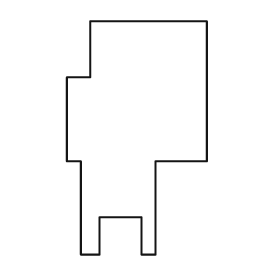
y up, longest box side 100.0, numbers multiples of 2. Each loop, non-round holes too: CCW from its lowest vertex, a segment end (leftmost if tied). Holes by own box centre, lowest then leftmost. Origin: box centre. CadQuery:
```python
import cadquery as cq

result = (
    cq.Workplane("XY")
    .moveTo(-24.0, -50.0)
    .lineTo(-16.0, -50.0)
    .lineTo(-16.0, -34.0)
    .lineTo(2.0, -34.0)
    .lineTo(2.0, -50.0)
    .lineTo(8.0, -50.0)
    .lineTo(8.0, -10.0)
    .lineTo(30.0, -10.0)
    .lineTo(30.0, 50.0)
    .lineTo(-20.0, 50.0)
    .lineTo(-20.0, 26.0)
    .lineTo(-30.0, 26.0)
    .lineTo(-30.0, -10.0)
    .lineTo(-24.0, -10.0)
    .close()
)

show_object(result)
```